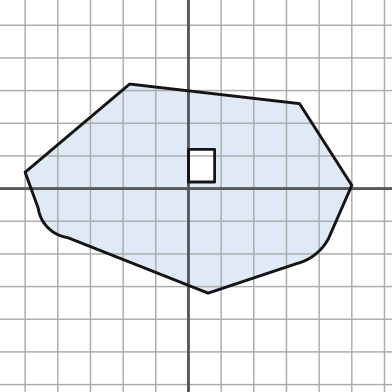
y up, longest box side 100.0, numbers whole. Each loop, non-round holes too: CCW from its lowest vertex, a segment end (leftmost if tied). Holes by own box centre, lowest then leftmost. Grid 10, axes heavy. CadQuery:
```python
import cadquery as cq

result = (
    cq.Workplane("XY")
    .moveTo(6.0, -32.0)
    .lineTo(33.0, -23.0)
    .threePointArc((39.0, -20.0), (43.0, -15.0))
    .lineTo(50.0, 1.0)
    .lineTo(34.0, 26.0)
    .lineTo(-18.0, 32.0)
    .lineTo(-50.0, 5.0)
    .lineTo(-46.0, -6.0)
    .threePointArc((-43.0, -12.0), (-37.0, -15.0))
    .close()
    .moveTo(0.0, 2.0)
    .lineTo(8.0, 2.0)
    .lineTo(8.0, 12.0)
    .lineTo(0.0, 12.0)
    .close()
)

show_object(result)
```